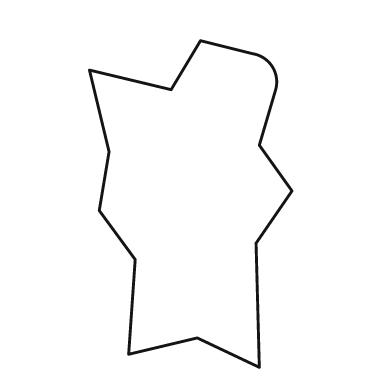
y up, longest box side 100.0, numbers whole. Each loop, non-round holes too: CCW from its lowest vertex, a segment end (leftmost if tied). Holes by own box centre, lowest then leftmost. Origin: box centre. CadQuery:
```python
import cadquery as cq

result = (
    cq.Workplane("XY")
    .moveTo(21.0, -50.0)
    .lineTo(20.0, -12.0)
    .lineTo(31.0, 4.0)
    .lineTo(21.0, 18.0)
    .lineTo(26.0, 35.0)
    .threePointArc((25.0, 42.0), (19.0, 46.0))
    .lineTo(3.0, 50.0)
    .lineTo(-6.0, 35.0)
    .lineTo(-31.0, 41.0)
    .lineTo(-25.0, 16.0)
    .lineTo(-28.0, -2.0)
    .lineTo(-17.0, -17.0)
    .lineTo(-19.0, -46.0)
    .lineTo(2.0, -41.0)
    .close()
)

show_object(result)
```